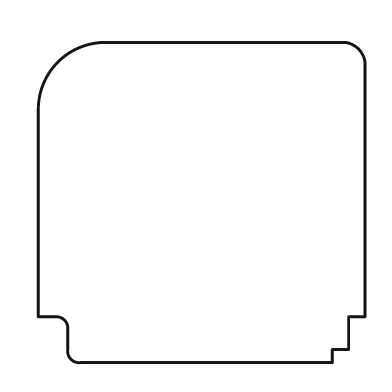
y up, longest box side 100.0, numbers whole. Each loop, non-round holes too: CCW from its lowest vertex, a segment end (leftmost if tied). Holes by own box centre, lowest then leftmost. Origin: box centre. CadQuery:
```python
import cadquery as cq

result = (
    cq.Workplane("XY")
    .moveTo(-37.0, -49.0)
    .lineTo(40.0, -49.0)
    .lineTo(40.0, -45.0)
    .lineTo(45.0, -45.0)
    .lineTo(45.0, -35.0)
    .lineTo(50.0, -35.0)
    .lineTo(50.0, 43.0)
    .threePointArc((48.0, 47.0), (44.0, 49.0))
    .lineTo(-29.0, 49.0)
    .threePointArc((-44.0, 43.0), (-50.0, 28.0))
    .lineTo(-50.0, -35.0)
    .lineTo(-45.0, -35.0)
    .threePointArc((-42.0, -36.0), (-41.0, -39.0))
    .lineTo(-41.0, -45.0)
    .threePointArc((-40.0, -48.0), (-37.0, -49.0))
    .close()
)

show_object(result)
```